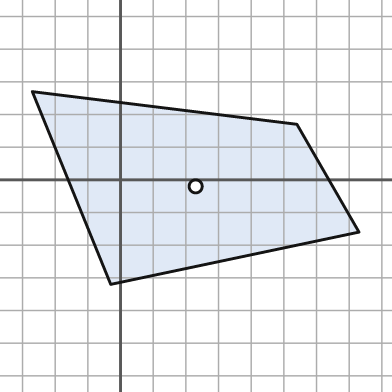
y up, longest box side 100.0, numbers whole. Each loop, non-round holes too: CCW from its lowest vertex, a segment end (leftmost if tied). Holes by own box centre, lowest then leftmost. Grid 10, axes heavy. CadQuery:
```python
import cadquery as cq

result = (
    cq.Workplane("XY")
    .moveTo(-3.0, -32.0)
    .lineTo(73.0, -16.0)
    .lineTo(54.0, 17.0)
    .lineTo(-27.0, 27.0)
    .close()
    .moveTo(23.0, -2.0)
    .circle(2.0)
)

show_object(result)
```